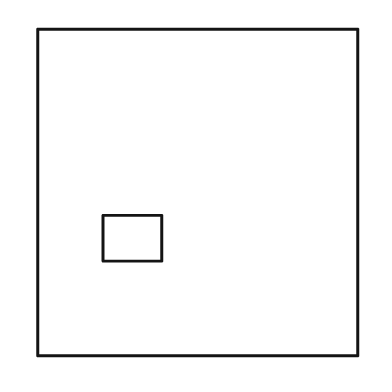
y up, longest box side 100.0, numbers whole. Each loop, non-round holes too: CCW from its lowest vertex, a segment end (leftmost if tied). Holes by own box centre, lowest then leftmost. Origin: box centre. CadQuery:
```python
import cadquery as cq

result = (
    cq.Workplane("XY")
    .moveTo(-49.0, -50.0)
    .lineTo(49.0, -50.0)
    .lineTo(49.0, 50.0)
    .lineTo(-49.0, 50.0)
    .close()
    .moveTo(-29.0, -21.0)
    .lineTo(-11.0, -21.0)
    .lineTo(-11.0, -7.0)
    .lineTo(-29.0, -7.0)
    .close()
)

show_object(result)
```